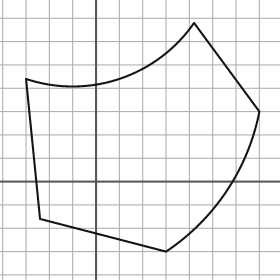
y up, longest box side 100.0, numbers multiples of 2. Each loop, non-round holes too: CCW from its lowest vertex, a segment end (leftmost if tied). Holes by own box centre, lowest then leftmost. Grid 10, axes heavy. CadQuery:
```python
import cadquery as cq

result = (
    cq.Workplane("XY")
    .moveTo(30.0, -30.0)
    .threePointArc((56.0, -4.0), (70.0, 30.0))
    .lineTo(42.0, 68.0)
    .threePointArc((10.0, 44.0), (-30.0, 44.0))
    .lineTo(-24.0, -16.0)
    .close()
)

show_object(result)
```